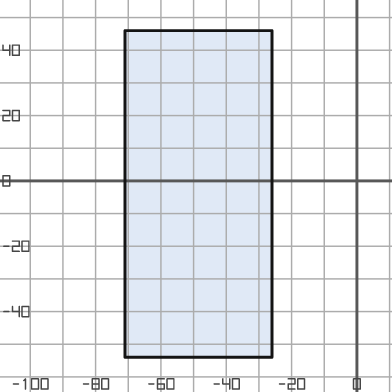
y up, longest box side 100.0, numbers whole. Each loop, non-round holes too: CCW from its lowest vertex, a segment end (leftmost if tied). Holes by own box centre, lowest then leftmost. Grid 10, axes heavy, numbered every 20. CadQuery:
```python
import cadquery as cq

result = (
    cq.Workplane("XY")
    .moveTo(-71.0, -54.0)
    .lineTo(-26.0, -54.0)
    .lineTo(-26.0, 46.0)
    .lineTo(-71.0, 46.0)
    .close()
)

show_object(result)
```